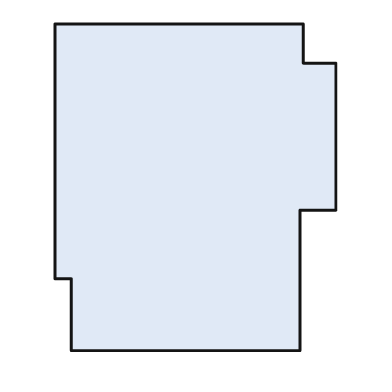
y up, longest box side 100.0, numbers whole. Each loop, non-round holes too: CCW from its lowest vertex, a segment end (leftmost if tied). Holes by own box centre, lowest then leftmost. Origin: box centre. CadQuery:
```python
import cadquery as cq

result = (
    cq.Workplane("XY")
    .moveTo(-38.0, -50.0)
    .lineTo(32.0, -50.0)
    .lineTo(32.0, -7.0)
    .lineTo(43.0, -7.0)
    .lineTo(43.0, 38.0)
    .lineTo(33.0, 38.0)
    .lineTo(33.0, 50.0)
    .lineTo(-43.0, 50.0)
    .lineTo(-43.0, -28.0)
    .lineTo(-38.0, -28.0)
    .close()
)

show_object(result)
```